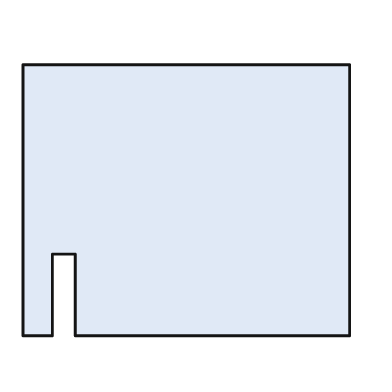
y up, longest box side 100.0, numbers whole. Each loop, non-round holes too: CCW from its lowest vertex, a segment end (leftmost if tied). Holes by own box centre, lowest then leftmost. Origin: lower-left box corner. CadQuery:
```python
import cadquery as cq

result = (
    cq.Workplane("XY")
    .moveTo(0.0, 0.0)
    .lineTo(9.0, 0.0)
    .lineTo(9.0, 25.0)
    .lineTo(16.0, 25.0)
    .lineTo(16.0, 0.0)
    .lineTo(100.0, 0.0)
    .lineTo(100.0, 83.0)
    .lineTo(0.0, 83.0)
    .close()
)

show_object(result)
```